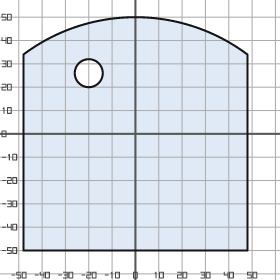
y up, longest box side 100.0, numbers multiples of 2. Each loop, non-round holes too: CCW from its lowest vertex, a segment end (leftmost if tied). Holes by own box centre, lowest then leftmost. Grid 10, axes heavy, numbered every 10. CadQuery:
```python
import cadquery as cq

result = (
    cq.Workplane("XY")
    .moveTo(-48.0, -50.0)
    .lineTo(48.0, -50.0)
    .lineTo(48.0, 34.0)
    .threePointArc((0.0, 50.0), (-48.0, 34.0))
    .close()
    .moveTo(-20.0, 26.0)
    .circle(6.0)
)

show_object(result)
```